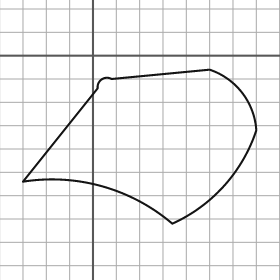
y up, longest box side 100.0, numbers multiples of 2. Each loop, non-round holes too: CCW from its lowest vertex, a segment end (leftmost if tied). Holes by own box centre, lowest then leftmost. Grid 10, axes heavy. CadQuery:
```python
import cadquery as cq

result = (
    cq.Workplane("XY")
    .moveTo(34.0, -72.0)
    .threePointArc((56.0, -56.0), (70.0, -32.0))
    .threePointArc((64.0, -16.0), (50.0, -6.0))
    .lineTo(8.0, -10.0)
    .threePointArc((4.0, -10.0), (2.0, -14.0))
    .lineTo(-30.0, -54.0)
    .threePointArc((4.0, -56.0), (34.0, -72.0))
    .close()
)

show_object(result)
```